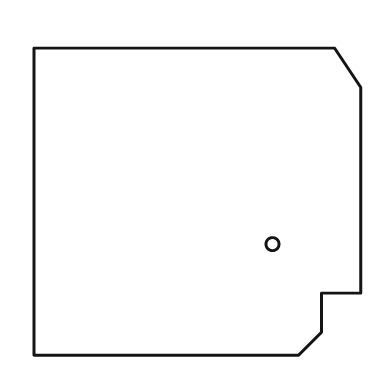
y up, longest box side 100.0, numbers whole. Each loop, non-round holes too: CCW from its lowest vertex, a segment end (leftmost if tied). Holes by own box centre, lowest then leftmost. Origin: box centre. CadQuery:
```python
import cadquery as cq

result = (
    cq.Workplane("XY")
    .moveTo(-50.0, -47.0)
    .lineTo(31.0, -47.0)
    .lineTo(38.0, -40.0)
    .lineTo(38.0, -28.0)
    .lineTo(50.0, -28.0)
    .lineTo(50.0, 35.0)
    .lineTo(42.0, 47.0)
    .lineTo(-50.0, 47.0)
    .close()
    .moveTo(23.0, -13.0)
    .circle(2.0)
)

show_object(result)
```